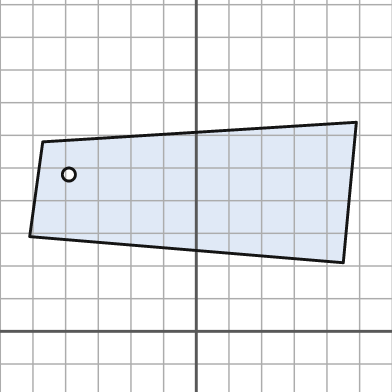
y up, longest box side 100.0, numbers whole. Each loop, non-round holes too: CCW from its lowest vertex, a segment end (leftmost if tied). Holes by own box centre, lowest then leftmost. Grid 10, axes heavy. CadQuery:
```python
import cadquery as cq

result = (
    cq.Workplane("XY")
    .moveTo(45.0, 21.0)
    .lineTo(49.0, 64.0)
    .lineTo(-47.0, 58.0)
    .lineTo(-51.0, 29.0)
    .close()
    .moveTo(-39.0, 48.0)
    .circle(2.0)
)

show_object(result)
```